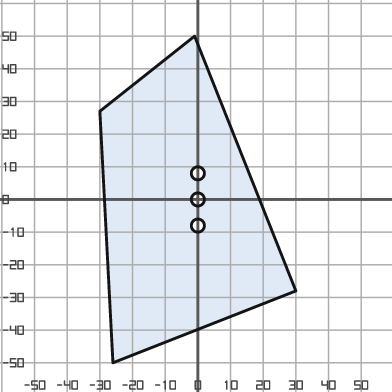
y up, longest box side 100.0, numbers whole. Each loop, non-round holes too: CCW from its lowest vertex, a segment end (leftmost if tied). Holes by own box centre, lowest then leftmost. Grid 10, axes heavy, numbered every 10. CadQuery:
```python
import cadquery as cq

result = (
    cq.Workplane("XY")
    .moveTo(-26.0, -50.0)
    .lineTo(30.0, -28.0)
    .lineTo(-1.0, 50.0)
    .lineTo(-30.0, 27.0)
    .close()
    .moveTo(0.0, -8.0)
    .circle(2.0)
    .moveTo(0.0, 0.0)
    .circle(2.0)
    .moveTo(0.0, 8.0)
    .circle(2.0)
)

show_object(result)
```